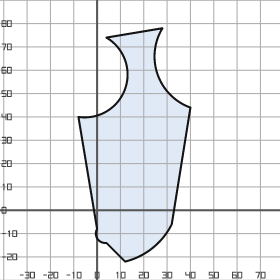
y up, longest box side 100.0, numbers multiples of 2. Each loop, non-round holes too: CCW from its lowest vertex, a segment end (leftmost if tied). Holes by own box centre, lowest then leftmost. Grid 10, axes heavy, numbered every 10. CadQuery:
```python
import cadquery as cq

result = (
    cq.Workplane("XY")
    .moveTo(12.0, -22.0)
    .threePointArc((24.0, -16.0), (32.0, -6.0))
    .lineTo(40.0, 44.0)
    .threePointArc((26.0, 58.0), (28.0, 78.0))
    .lineTo(4.0, 74.0)
    .threePointArc((12.0, 52.0), (-8.0, 40.0))
    .lineTo(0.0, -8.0)
    .threePointArc((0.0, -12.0), (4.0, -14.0))
    .close()
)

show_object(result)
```